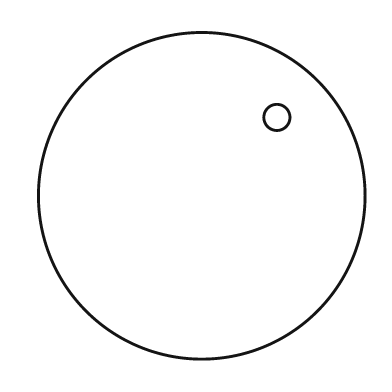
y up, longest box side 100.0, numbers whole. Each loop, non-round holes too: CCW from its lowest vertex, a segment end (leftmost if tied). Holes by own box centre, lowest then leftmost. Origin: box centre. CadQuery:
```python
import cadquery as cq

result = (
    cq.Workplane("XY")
    .moveTo(0.0, 0.0)
    .circle(50.0)
    .moveTo(23.0, 24.0)
    .circle(4.0)
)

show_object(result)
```